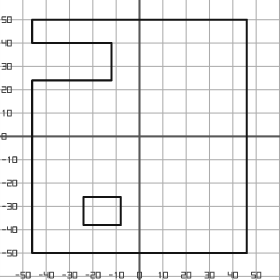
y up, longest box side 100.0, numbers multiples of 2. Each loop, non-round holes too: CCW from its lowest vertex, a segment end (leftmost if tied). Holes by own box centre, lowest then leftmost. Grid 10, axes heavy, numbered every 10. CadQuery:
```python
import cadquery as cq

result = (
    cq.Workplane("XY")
    .moveTo(-46.0, -50.0)
    .lineTo(46.0, -50.0)
    .lineTo(46.0, 50.0)
    .lineTo(-46.0, 50.0)
    .lineTo(-46.0, 40.0)
    .lineTo(-12.0, 40.0)
    .lineTo(-12.0, 24.0)
    .lineTo(-46.0, 24.0)
    .close()
    .moveTo(-24.0, -38.0)
    .lineTo(-8.0, -38.0)
    .lineTo(-8.0, -26.0)
    .lineTo(-24.0, -26.0)
    .close()
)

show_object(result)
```